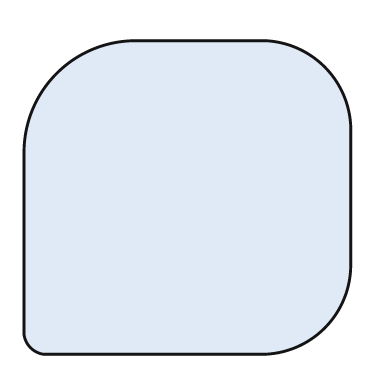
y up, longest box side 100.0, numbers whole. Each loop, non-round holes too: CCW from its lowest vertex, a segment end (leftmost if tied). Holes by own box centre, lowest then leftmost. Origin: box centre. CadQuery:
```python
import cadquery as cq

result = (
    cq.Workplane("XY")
    .moveTo(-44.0, -48.0)
    .lineTo(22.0, -48.0)
    .threePointArc((42.0, -40.0), (50.0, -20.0))
    .lineTo(50.0, 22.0)
    .threePointArc((42.0, 40.0), (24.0, 48.0))
    .lineTo(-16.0, 48.0)
    .threePointArc((-40.0, 38.0), (-50.0, 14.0))
    .lineTo(-50.0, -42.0)
    .threePointArc((-48.0, -46.0), (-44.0, -48.0))
    .close()
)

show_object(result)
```